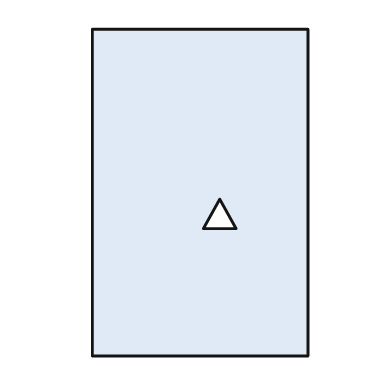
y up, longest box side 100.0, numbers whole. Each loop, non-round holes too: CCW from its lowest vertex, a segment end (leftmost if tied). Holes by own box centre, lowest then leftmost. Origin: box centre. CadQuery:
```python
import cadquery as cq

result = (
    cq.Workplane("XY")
    .moveTo(-33.0, -50.0)
    .lineTo(33.0, -50.0)
    .lineTo(33.0, 50.0)
    .lineTo(-33.0, 50.0)
    .close()
    .moveTo(1.0, -11.0)
    .lineTo(11.0, -11.0)
    .lineTo(6.0, -2.0)
    .close()
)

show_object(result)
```